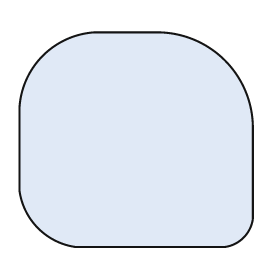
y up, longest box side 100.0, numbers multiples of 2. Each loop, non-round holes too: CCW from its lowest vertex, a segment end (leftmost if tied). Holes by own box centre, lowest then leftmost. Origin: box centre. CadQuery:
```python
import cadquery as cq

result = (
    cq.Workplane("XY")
    .moveTo(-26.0, -46.0)
    .lineTo(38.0, -46.0)
    .threePointArc((46.0, -42.0), (50.0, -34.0))
    .lineTo(50.0, 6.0)
    .threePointArc((38.0, 34.0), (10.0, 46.0))
    .lineTo(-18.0, 46.0)
    .threePointArc((-40.0, 36.0), (-50.0, 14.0))
    .lineTo(-50.0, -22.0)
    .threePointArc((-42.0, -38.0), (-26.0, -46.0))
    .close()
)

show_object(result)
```